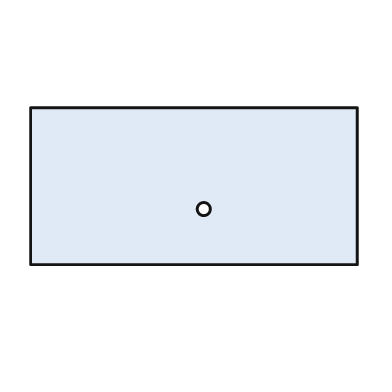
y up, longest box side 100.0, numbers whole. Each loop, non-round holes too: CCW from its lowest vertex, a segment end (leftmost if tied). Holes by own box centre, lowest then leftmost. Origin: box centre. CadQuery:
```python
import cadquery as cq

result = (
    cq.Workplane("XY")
    .moveTo(-50.0, -24.0)
    .lineTo(50.0, -24.0)
    .lineTo(50.0, 24.0)
    .lineTo(-50.0, 24.0)
    .close()
    .moveTo(3.0, -7.0)
    .circle(2.0)
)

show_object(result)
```